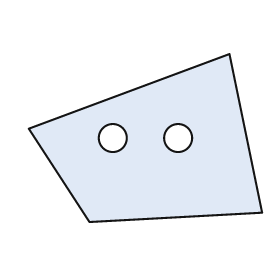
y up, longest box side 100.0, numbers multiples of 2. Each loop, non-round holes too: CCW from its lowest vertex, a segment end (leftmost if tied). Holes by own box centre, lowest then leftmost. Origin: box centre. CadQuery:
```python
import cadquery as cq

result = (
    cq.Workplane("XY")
    .moveTo(-24.0, -36.0)
    .lineTo(50.0, -32.0)
    .lineTo(36.0, 36.0)
    .lineTo(-50.0, 4.0)
    .close()
    .moveTo(-14.0, 0.0)
    .circle(6.0)
    .moveTo(14.0, 0.0)
    .circle(6.0)
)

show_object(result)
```